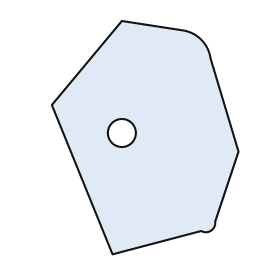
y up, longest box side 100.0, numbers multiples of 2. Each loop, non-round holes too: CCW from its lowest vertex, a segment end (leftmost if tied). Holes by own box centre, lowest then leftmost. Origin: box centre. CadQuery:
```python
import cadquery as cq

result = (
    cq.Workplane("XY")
    .moveTo(-14.0, -50.0)
    .lineTo(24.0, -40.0)
    .threePointArc((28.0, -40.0), (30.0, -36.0))
    .lineTo(40.0, -6.0)
    .lineTo(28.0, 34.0)
    .threePointArc((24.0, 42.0), (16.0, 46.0))
    .lineTo(-10.0, 50.0)
    .lineTo(-40.0, 14.0)
    .close()
    .moveTo(-10.0, 2.0)
    .circle(6.0)
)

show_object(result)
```